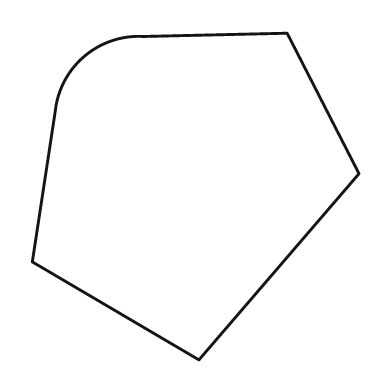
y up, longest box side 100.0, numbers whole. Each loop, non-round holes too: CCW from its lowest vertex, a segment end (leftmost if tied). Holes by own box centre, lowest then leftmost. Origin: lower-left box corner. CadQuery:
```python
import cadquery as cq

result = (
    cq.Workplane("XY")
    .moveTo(51.0, 0.0)
    .lineTo(100.0, 57.0)
    .lineTo(78.0, 100.0)
    .lineTo(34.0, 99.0)
    .threePointArc((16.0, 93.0), (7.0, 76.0))
    .lineTo(0.0, 30.0)
    .close()
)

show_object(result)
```